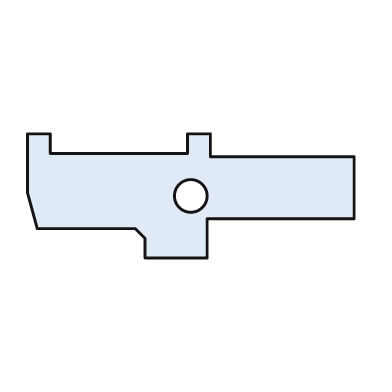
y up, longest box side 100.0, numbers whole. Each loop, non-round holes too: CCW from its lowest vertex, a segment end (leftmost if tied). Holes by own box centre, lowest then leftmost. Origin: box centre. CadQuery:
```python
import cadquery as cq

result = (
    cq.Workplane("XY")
    .moveTo(-14.0, -19.0)
    .lineTo(5.0, -19.0)
    .lineTo(5.0, -7.0)
    .lineTo(50.0, -7.0)
    .lineTo(50.0, 12.0)
    .lineTo(6.0, 12.0)
    .lineTo(6.0, 19.0)
    .lineTo(-1.0, 19.0)
    .lineTo(-1.0, 13.0)
    .lineTo(-43.0, 13.0)
    .lineTo(-43.0, 19.0)
    .lineTo(-50.0, 19.0)
    .lineTo(-50.0, 1.0)
    .lineTo(-47.0, -10.0)
    .lineTo(-17.0, -10.0)
    .lineTo(-14.0, -13.0)
    .close()
    .moveTo(0.0, 0.0)
    .circle(5.0)
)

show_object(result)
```